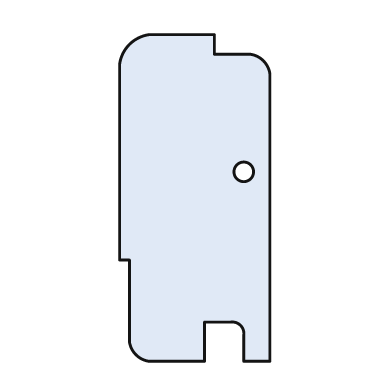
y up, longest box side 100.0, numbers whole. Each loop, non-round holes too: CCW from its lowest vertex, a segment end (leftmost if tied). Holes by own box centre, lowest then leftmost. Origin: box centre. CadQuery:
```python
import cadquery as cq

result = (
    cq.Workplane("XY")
    .moveTo(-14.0, -50.0)
    .lineTo(3.0, -50.0)
    .lineTo(3.0, -38.0)
    .lineTo(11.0, -38.0)
    .threePointArc((14.0, -39.0), (15.0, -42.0))
    .lineTo(15.0, -50.0)
    .lineTo(23.0, -50.0)
    .lineTo(23.0, 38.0)
    .threePointArc((21.0, 42.0), (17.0, 44.0))
    .lineTo(6.0, 44.0)
    .lineTo(6.0, 50.0)
    .lineTo(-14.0, 50.0)
    .threePointArc((-20.0, 47.0), (-23.0, 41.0))
    .lineTo(-23.0, -19.0)
    .lineTo(-20.0, -19.0)
    .lineTo(-20.0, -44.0)
    .threePointArc((-18.0, -48.0), (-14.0, -50.0))
    .close()
    .moveTo(15.0, 8.0)
    .circle(3.0)
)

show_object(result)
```